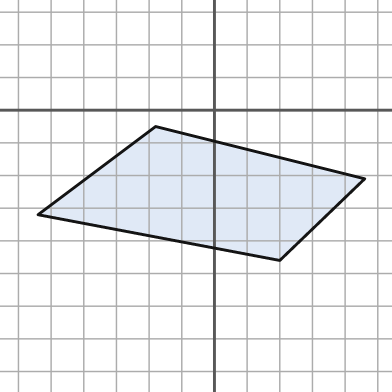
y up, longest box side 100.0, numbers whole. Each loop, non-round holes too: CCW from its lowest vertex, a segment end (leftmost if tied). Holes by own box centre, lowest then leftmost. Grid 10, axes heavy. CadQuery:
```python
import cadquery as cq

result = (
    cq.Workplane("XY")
    .moveTo(20.0, -46.0)
    .lineTo(46.0, -21.0)
    .lineTo(-18.0, -5.0)
    .lineTo(-54.0, -32.0)
    .close()
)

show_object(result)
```